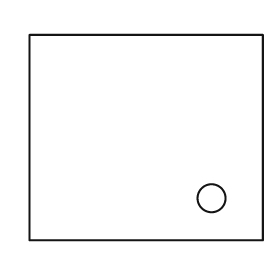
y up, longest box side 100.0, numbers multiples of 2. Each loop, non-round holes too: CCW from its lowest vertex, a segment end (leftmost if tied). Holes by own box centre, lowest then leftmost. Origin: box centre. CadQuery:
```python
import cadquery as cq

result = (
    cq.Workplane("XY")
    .moveTo(-50.0, -44.0)
    .lineTo(50.0, -44.0)
    .lineTo(50.0, 44.0)
    .lineTo(-50.0, 44.0)
    .close()
    .moveTo(28.0, -26.0)
    .circle(6.0)
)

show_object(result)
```